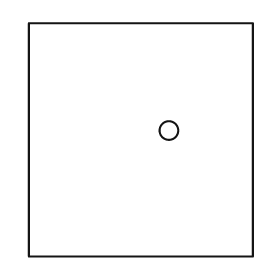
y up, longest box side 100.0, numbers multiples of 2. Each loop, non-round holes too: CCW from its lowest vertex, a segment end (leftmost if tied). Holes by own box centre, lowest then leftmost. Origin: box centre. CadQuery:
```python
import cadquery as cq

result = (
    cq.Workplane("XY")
    .moveTo(-48.0, -50.0)
    .lineTo(48.0, -50.0)
    .lineTo(48.0, 50.0)
    .lineTo(-48.0, 50.0)
    .close()
    .moveTo(12.0, 4.0)
    .circle(4.0)
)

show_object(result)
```